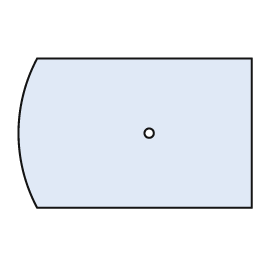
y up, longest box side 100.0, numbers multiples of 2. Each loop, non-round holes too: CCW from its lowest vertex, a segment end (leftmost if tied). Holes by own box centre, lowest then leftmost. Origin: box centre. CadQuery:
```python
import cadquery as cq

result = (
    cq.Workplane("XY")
    .moveTo(-42.0, -32.0)
    .lineTo(50.0, -32.0)
    .lineTo(50.0, 32.0)
    .lineTo(-42.0, 32.0)
    .threePointArc((-50.0, 0.0), (-42.0, -32.0))
    .close()
    .moveTo(6.0, 0.0)
    .circle(2.0)
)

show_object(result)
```